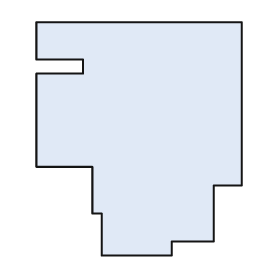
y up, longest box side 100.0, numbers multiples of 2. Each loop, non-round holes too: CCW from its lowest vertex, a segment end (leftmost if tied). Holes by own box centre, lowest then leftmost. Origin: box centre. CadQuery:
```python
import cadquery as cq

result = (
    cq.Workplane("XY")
    .moveTo(-16.0, -50.0)
    .lineTo(14.0, -50.0)
    .lineTo(14.0, -44.0)
    .lineTo(32.0, -44.0)
    .lineTo(32.0, -20.0)
    .lineTo(44.0, -20.0)
    .lineTo(44.0, 50.0)
    .lineTo(-44.0, 50.0)
    .lineTo(-44.0, 34.0)
    .lineTo(-24.0, 34.0)
    .lineTo(-24.0, 28.0)
    .lineTo(-44.0, 28.0)
    .lineTo(-44.0, -12.0)
    .lineTo(-20.0, -12.0)
    .lineTo(-20.0, -32.0)
    .lineTo(-16.0, -32.0)
    .close()
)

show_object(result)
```